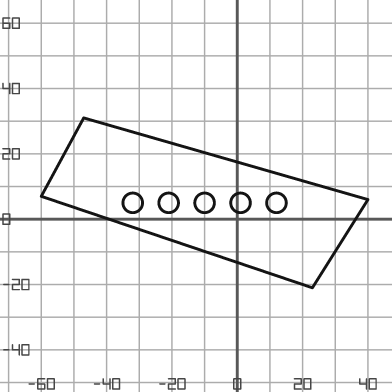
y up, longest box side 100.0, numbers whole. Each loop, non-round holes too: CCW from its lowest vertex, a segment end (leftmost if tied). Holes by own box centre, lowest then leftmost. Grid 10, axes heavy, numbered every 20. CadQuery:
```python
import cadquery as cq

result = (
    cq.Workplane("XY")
    .moveTo(23.0, -21.0)
    .lineTo(40.0, 6.0)
    .lineTo(-47.0, 31.0)
    .lineTo(-60.0, 7.0)
    .close()
    .moveTo(-32.0, 5.0)
    .circle(3.0)
    .moveTo(-21.0, 5.0)
    .circle(3.0)
    .moveTo(-10.0, 5.0)
    .circle(3.0)
    .moveTo(1.0, 5.0)
    .circle(3.0)
    .moveTo(12.0, 5.0)
    .circle(3.0)
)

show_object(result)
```